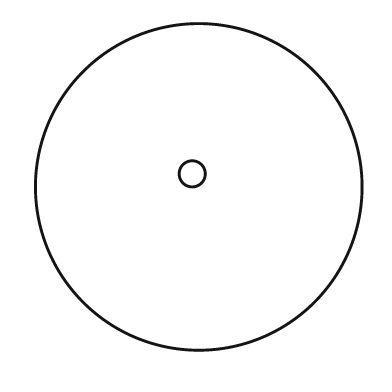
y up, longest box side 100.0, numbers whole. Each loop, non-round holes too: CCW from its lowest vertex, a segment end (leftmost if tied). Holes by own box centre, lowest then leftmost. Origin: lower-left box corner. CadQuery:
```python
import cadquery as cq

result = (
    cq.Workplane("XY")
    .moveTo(50.0, 50.0)
    .circle(50.0)
    .moveTo(48.0, 54.0)
    .circle(4.0)
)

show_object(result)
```